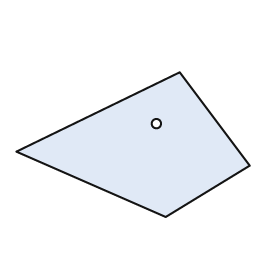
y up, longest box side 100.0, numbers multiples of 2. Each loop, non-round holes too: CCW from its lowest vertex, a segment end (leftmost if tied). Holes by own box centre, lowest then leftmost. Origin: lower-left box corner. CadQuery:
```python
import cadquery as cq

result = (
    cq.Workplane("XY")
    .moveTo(64.0, 0.0)
    .lineTo(100.0, 22.0)
    .lineTo(70.0, 62.0)
    .lineTo(0.0, 28.0)
    .close()
    .moveTo(60.0, 40.0)
    .circle(2.0)
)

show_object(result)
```